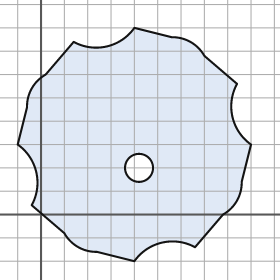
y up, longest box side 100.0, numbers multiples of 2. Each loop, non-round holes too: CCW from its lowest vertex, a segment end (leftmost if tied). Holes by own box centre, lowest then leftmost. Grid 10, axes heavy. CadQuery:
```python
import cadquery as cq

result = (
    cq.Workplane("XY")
    .moveTo(40.0, -20.0)
    .threePointArc((52.0, -12.0), (66.0, -14.0))
    .lineTo(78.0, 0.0)
    .threePointArc((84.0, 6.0), (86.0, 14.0))
    .lineTo(90.0, 30.0)
    .threePointArc((82.0, 42.0), (84.0, 56.0))
    .lineTo(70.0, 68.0)
    .threePointArc((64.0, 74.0), (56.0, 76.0))
    .lineTo(40.0, 80.0)
    .threePointArc((28.0, 72.0), (14.0, 74.0))
    .lineTo(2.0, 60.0)
    .threePointArc((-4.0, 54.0), (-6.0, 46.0))
    .lineTo(-10.0, 30.0)
    .threePointArc((-2.0, 18.0), (-4.0, 4.0))
    .lineTo(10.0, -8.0)
    .threePointArc((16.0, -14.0), (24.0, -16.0))
    .close()
    .moveTo(42.0, 20.0)
    .circle(6.0)
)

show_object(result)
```